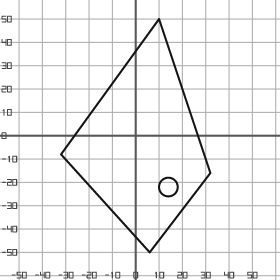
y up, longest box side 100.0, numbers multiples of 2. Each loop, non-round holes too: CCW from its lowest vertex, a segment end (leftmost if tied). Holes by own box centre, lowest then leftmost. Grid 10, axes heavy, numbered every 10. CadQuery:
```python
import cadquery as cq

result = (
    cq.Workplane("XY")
    .moveTo(6.0, -50.0)
    .lineTo(32.0, -16.0)
    .lineTo(10.0, 50.0)
    .lineTo(-32.0, -8.0)
    .close()
    .moveTo(14.0, -22.0)
    .circle(4.0)
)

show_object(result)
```